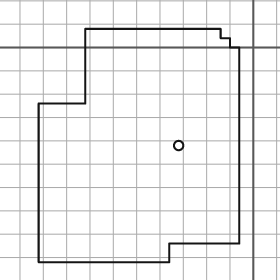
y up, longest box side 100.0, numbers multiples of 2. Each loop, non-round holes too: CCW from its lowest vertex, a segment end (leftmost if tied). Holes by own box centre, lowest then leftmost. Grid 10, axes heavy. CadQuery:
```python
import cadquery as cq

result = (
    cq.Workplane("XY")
    .moveTo(-92.0, -92.0)
    .lineTo(-36.0, -92.0)
    .lineTo(-36.0, -84.0)
    .lineTo(-6.0, -84.0)
    .lineTo(-6.0, 0.0)
    .lineTo(-10.0, 0.0)
    .lineTo(-10.0, 4.0)
    .lineTo(-14.0, 4.0)
    .lineTo(-14.0, 8.0)
    .lineTo(-72.0, 8.0)
    .lineTo(-72.0, -24.0)
    .lineTo(-92.0, -24.0)
    .close()
    .moveTo(-32.0, -42.0)
    .circle(2.0)
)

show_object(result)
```